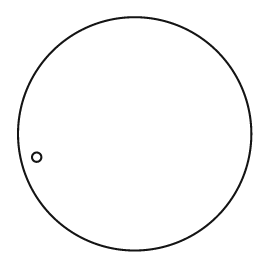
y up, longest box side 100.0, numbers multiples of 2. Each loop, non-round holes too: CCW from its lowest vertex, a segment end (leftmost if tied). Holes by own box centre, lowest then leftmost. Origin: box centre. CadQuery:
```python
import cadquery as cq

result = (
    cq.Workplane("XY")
    .moveTo(0.0, 0.0)
    .circle(50.0)
    .moveTo(-42.0, -10.0)
    .circle(2.0)
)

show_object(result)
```